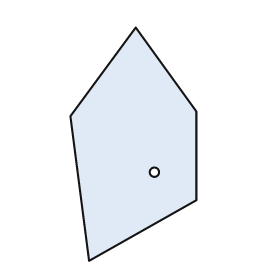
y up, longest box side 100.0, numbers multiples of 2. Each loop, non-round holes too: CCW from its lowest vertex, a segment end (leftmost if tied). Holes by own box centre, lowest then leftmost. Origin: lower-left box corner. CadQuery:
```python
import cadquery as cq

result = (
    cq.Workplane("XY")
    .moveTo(8.0, 0.0)
    .lineTo(54.0, 26.0)
    .lineTo(54.0, 64.0)
    .lineTo(28.0, 100.0)
    .lineTo(0.0, 62.0)
    .close()
    .moveTo(36.0, 38.0)
    .circle(2.0)
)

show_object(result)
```